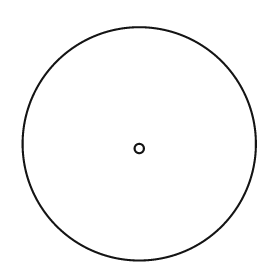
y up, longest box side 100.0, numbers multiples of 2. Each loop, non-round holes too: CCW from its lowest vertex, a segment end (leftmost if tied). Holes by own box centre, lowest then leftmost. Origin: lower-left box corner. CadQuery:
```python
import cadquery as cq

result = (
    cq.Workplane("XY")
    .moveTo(50.0, 50.0)
    .circle(50.0)
    .moveTo(50.0, 48.0)
    .circle(2.0)
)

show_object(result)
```